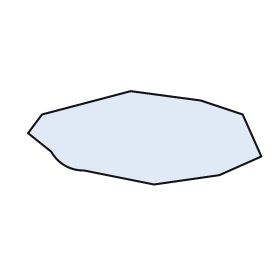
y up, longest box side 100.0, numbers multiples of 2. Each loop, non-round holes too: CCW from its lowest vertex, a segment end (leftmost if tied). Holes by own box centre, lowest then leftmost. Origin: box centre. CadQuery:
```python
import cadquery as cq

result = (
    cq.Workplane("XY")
    .moveTo(4.0, -20.0)
    .lineTo(32.0, -16.0)
    .lineTo(50.0, -8.0)
    .lineTo(42.0, 10.0)
    .lineTo(24.0, 16.0)
    .lineTo(-6.0, 20.0)
    .lineTo(-44.0, 10.0)
    .lineTo(-50.0, 2.0)
    .lineTo(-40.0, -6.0)
    .threePointArc((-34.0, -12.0), (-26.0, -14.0))
    .close()
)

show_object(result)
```